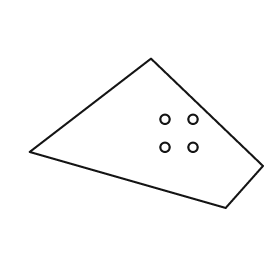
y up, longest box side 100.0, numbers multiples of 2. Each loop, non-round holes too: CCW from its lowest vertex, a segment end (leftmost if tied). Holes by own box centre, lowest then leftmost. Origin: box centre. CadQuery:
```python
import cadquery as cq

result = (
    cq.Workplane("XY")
    .moveTo(34.0, -32.0)
    .lineTo(50.0, -14.0)
    .lineTo(2.0, 32.0)
    .lineTo(-50.0, -8.0)
    .close()
    .moveTo(8.0, -6.0)
    .circle(2.0)
    .moveTo(20.0, -6.0)
    .circle(2.0)
    .moveTo(8.0, 6.0)
    .circle(2.0)
    .moveTo(20.0, 6.0)
    .circle(2.0)
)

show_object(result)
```